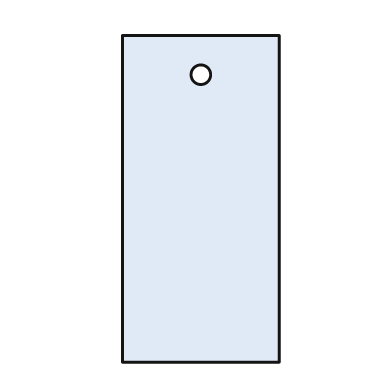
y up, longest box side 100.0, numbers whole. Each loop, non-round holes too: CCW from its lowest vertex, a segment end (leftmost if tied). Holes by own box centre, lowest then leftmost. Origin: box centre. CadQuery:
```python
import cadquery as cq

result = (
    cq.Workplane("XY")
    .moveTo(-24.0, -50.0)
    .lineTo(24.0, -50.0)
    .lineTo(24.0, 50.0)
    .lineTo(-24.0, 50.0)
    .close()
    .moveTo(0.0, 38.0)
    .circle(3.0)
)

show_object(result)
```